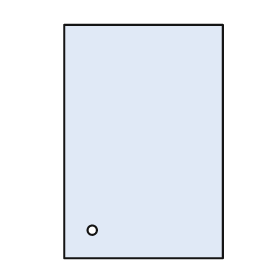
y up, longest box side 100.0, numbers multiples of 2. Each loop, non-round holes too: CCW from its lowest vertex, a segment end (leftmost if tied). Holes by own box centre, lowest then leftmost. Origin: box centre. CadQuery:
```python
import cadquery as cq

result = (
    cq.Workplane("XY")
    .moveTo(-34.0, -50.0)
    .lineTo(34.0, -50.0)
    .lineTo(34.0, 50.0)
    .lineTo(-34.0, 50.0)
    .close()
    .moveTo(-22.0, -38.0)
    .circle(2.0)
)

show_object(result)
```